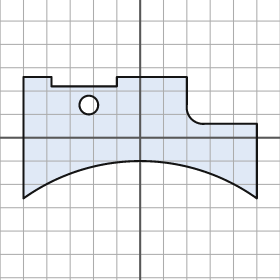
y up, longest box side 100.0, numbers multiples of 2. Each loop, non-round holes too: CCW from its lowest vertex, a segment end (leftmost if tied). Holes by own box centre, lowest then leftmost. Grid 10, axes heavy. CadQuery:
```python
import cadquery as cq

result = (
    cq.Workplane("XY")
    .moveTo(-50.0, -26.0)
    .threePointArc((0.0, -10.0), (50.0, -26.0))
    .lineTo(50.0, 6.0)
    .lineTo(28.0, 6.0)
    .threePointArc((22.0, 8.0), (20.0, 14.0))
    .lineTo(20.0, 26.0)
    .lineTo(-10.0, 26.0)
    .lineTo(-10.0, 22.0)
    .lineTo(-38.0, 22.0)
    .lineTo(-38.0, 26.0)
    .lineTo(-50.0, 26.0)
    .close()
    .moveTo(-22.0, 14.0)
    .circle(4.0)
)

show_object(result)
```